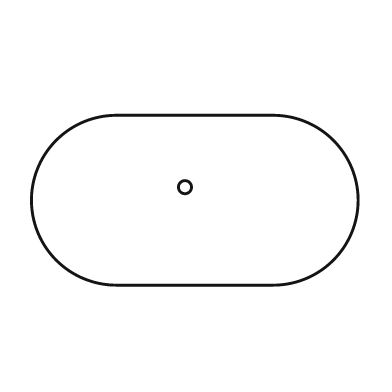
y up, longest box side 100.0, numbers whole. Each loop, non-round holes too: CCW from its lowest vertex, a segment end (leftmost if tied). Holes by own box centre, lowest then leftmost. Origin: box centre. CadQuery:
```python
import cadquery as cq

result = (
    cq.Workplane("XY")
    .moveTo(-24.0, -26.0)
    .lineTo(24.0, -26.0)
    .threePointArc((50.0, 0.0), (24.0, 26.0))
    .lineTo(-24.0, 26.0)
    .threePointArc((-50.0, 0.0), (-24.0, -26.0))
    .close()
    .moveTo(-3.0, 4.0)
    .circle(2.0)
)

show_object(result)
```